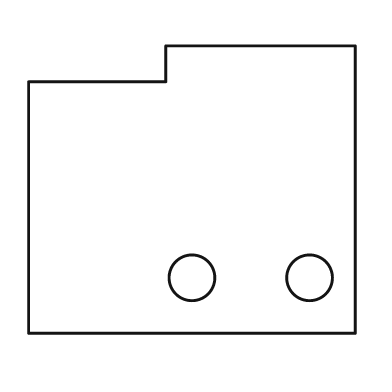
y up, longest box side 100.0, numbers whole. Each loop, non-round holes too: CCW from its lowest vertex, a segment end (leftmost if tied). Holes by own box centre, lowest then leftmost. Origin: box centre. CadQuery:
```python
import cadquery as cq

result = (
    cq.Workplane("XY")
    .moveTo(-50.0, -44.0)
    .lineTo(50.0, -44.0)
    .lineTo(50.0, 44.0)
    .lineTo(-8.0, 44.0)
    .lineTo(-8.0, 33.0)
    .lineTo(-50.0, 33.0)
    .close()
    .moveTo(0.0, -27.0)
    .circle(7.0)
    .moveTo(36.0, -27.0)
    .circle(7.0)
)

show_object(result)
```